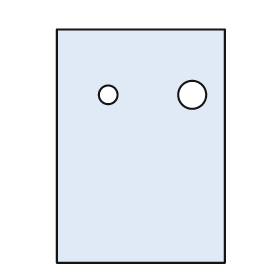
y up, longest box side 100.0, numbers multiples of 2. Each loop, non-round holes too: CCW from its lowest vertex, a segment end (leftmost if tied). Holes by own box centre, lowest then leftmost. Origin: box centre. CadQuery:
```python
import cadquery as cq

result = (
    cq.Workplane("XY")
    .moveTo(-36.0, -50.0)
    .lineTo(36.0, -50.0)
    .lineTo(36.0, 50.0)
    .lineTo(-36.0, 50.0)
    .close()
    .moveTo(-14.0, 22.0)
    .circle(4.0)
    .moveTo(22.0, 22.0)
    .circle(6.0)
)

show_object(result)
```